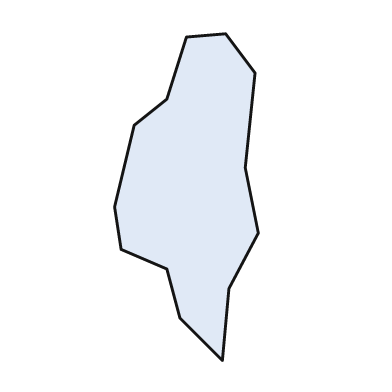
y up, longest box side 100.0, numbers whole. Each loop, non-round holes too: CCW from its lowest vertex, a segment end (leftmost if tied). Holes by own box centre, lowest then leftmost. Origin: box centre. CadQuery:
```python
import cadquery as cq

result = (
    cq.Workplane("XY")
    .moveTo(11.0, -50.0)
    .lineTo(13.0, -28.0)
    .lineTo(22.0, -11.0)
    .lineTo(18.0, 9.0)
    .lineTo(21.0, 38.0)
    .lineTo(12.0, 50.0)
    .lineTo(0.0, 49.0)
    .lineTo(-6.0, 30.0)
    .lineTo(-16.0, 22.0)
    .lineTo(-22.0, -3.0)
    .lineTo(-20.0, -16.0)
    .lineTo(-6.0, -22.0)
    .lineTo(-2.0, -37.0)
    .close()
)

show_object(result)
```